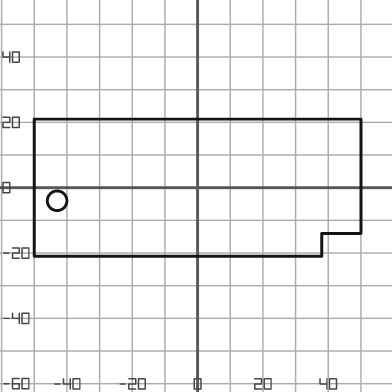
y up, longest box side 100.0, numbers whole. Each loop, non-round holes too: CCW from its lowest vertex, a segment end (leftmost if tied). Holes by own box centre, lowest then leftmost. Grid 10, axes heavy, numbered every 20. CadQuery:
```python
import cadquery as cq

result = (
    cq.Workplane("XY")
    .moveTo(-50.0, -21.0)
    .lineTo(38.0, -21.0)
    .lineTo(38.0, -14.0)
    .lineTo(50.0, -14.0)
    .lineTo(50.0, 21.0)
    .lineTo(-50.0, 21.0)
    .close()
    .moveTo(-43.0, -4.0)
    .circle(3.0)
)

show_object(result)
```